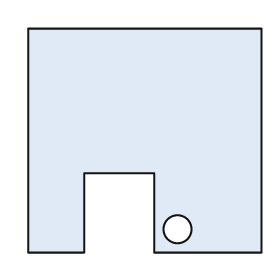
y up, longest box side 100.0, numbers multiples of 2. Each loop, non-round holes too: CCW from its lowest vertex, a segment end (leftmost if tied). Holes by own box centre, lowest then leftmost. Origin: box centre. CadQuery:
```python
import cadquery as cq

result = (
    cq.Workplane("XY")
    .moveTo(-50.0, -48.0)
    .lineTo(-26.0, -48.0)
    .lineTo(-26.0, -14.0)
    .lineTo(4.0, -14.0)
    .lineTo(4.0, -48.0)
    .lineTo(50.0, -48.0)
    .lineTo(50.0, 48.0)
    .lineTo(-50.0, 48.0)
    .close()
    .moveTo(14.0, -38.0)
    .circle(6.0)
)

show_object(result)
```